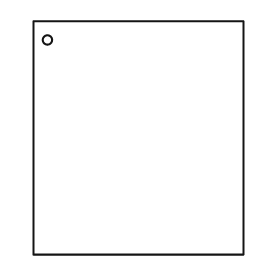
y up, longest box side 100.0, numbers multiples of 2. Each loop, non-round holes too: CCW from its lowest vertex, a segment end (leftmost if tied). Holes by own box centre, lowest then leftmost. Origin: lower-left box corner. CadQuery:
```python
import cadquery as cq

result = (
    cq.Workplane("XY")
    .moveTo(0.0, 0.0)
    .lineTo(90.0, 0.0)
    .lineTo(90.0, 100.0)
    .lineTo(0.0, 100.0)
    .close()
    .moveTo(6.0, 92.0)
    .circle(2.0)
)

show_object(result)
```